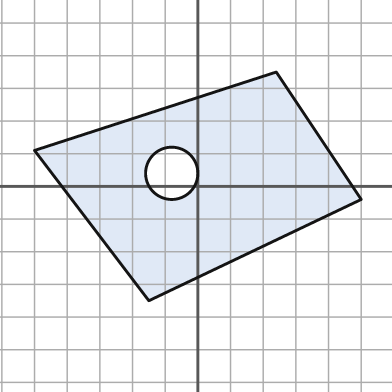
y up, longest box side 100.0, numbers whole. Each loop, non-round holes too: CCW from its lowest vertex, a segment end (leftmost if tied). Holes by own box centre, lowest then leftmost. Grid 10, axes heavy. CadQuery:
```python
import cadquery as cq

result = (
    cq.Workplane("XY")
    .moveTo(-15.0, -35.0)
    .lineTo(50.0, -4.0)
    .lineTo(24.0, 35.0)
    .lineTo(-50.0, 11.0)
    .close()
    .moveTo(-8.0, 4.0)
    .circle(8.0)
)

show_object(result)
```